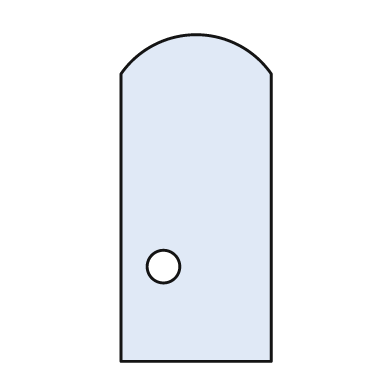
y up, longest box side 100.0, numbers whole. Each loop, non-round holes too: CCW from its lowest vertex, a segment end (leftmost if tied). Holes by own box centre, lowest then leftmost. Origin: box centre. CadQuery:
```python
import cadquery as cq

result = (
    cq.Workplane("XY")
    .moveTo(-23.0, -50.0)
    .lineTo(23.0, -50.0)
    .lineTo(23.0, 38.0)
    .threePointArc((0.0, 50.0), (-23.0, 38.0))
    .close()
    .moveTo(-10.0, -21.0)
    .circle(5.0)
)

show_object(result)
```